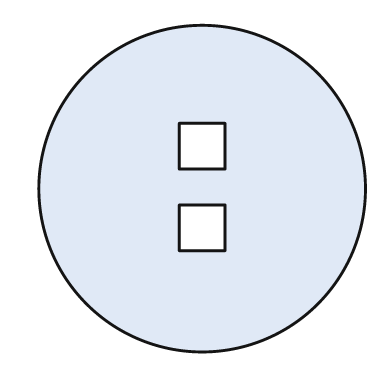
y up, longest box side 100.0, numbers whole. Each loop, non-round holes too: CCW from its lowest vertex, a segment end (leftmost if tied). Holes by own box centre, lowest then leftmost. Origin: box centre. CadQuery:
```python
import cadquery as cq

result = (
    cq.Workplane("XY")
    .moveTo(0.0, 0.0)
    .circle(50.0)
    .moveTo(-7.0, -19.0)
    .lineTo(7.0, -19.0)
    .lineTo(7.0, -5.0)
    .lineTo(-7.0, -5.0)
    .close()
    .moveTo(-7.0, 6.0)
    .lineTo(7.0, 6.0)
    .lineTo(7.0, 20.0)
    .lineTo(-7.0, 20.0)
    .close()
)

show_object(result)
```